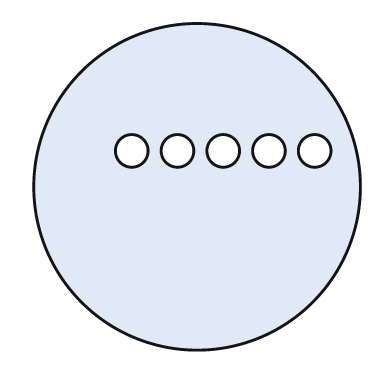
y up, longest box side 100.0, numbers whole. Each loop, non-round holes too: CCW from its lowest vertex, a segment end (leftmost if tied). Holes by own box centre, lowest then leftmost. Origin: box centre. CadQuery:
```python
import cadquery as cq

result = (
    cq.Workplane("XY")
    .moveTo(0.0, 0.0)
    .circle(50.0)
    .moveTo(-20.0, 11.0)
    .circle(5.0)
    .moveTo(-6.0, 11.0)
    .circle(5.0)
    .moveTo(8.0, 11.0)
    .circle(5.0)
    .moveTo(22.0, 11.0)
    .circle(5.0)
    .moveTo(36.0, 11.0)
    .circle(5.0)
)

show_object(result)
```